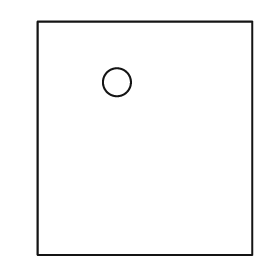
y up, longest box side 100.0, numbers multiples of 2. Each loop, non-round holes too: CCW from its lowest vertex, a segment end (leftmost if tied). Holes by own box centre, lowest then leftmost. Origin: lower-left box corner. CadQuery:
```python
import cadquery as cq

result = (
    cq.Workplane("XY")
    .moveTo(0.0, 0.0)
    .lineTo(92.0, 0.0)
    .lineTo(92.0, 100.0)
    .lineTo(0.0, 100.0)
    .close()
    .moveTo(34.0, 74.0)
    .circle(6.0)
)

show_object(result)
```